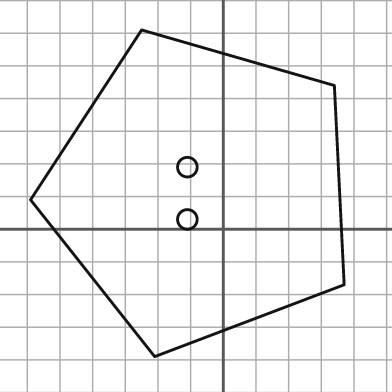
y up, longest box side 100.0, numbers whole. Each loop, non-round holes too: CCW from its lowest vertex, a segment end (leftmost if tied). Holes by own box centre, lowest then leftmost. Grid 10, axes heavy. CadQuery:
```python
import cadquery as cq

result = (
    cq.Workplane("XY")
    .moveTo(-21.0, -39.0)
    .lineTo(37.0, -17.0)
    .lineTo(34.0, 44.0)
    .lineTo(-25.0, 61.0)
    .lineTo(-59.0, 9.0)
    .close()
    .moveTo(-11.0, 3.0)
    .circle(3.0)
    .moveTo(-11.0, 19.0)
    .circle(3.0)
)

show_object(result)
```